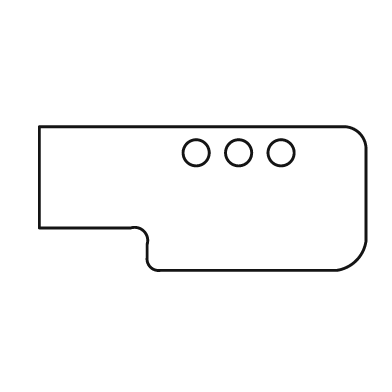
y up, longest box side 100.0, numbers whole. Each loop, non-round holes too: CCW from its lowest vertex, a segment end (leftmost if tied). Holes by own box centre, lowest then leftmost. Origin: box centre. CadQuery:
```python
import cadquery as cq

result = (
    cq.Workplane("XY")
    .moveTo(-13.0, -22.0)
    .lineTo(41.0, -22.0)
    .threePointArc((47.0, -19.0), (50.0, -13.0))
    .lineTo(50.0, 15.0)
    .threePointArc((48.0, 20.0), (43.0, 22.0))
    .lineTo(-50.0, 22.0)
    .lineTo(-50.0, -9.0)
    .lineTo(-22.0, -9.0)
    .threePointArc((-18.0, -10.0), (-17.0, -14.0))
    .lineTo(-17.0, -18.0)
    .threePointArc((-16.0, -21.0), (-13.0, -22.0))
    .close()
    .moveTo(-2.0, 14.0)
    .circle(4.0)
    .moveTo(11.0, 14.0)
    .circle(4.0)
    .moveTo(24.0, 14.0)
    .circle(4.0)
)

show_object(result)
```